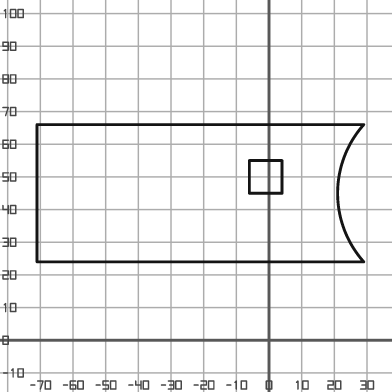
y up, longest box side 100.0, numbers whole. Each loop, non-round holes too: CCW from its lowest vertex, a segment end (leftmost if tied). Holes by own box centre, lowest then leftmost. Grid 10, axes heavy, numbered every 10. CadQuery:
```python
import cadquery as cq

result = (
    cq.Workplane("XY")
    .moveTo(-71.0, 24.0)
    .lineTo(29.0, 24.0)
    .threePointArc((21.0, 45.0), (29.0, 66.0))
    .lineTo(-71.0, 66.0)
    .close()
    .moveTo(-6.0, 45.0)
    .lineTo(4.0, 45.0)
    .lineTo(4.0, 55.0)
    .lineTo(-6.0, 55.0)
    .close()
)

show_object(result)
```